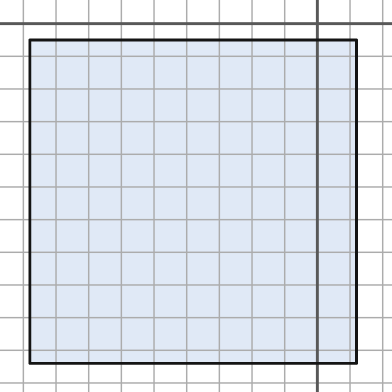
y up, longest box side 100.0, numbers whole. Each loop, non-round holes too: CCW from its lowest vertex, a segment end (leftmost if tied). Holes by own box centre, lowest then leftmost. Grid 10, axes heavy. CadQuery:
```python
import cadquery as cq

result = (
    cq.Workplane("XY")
    .moveTo(-88.0, -104.0)
    .lineTo(12.0, -104.0)
    .lineTo(12.0, -5.0)
    .lineTo(-88.0, -5.0)
    .close()
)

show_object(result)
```